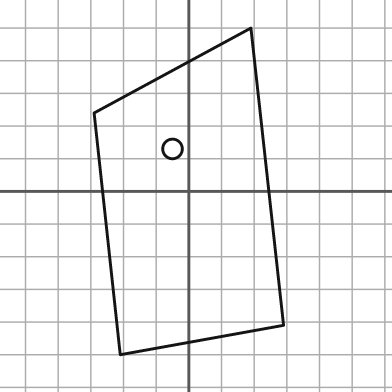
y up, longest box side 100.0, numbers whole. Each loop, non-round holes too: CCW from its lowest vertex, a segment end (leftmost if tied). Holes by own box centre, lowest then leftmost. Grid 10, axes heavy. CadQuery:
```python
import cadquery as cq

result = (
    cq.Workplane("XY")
    .moveTo(-21.0, -50.0)
    .lineTo(29.0, -41.0)
    .lineTo(19.0, 50.0)
    .lineTo(-29.0, 24.0)
    .close()
    .moveTo(-5.0, 13.0)
    .circle(3.0)
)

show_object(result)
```